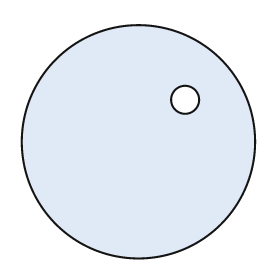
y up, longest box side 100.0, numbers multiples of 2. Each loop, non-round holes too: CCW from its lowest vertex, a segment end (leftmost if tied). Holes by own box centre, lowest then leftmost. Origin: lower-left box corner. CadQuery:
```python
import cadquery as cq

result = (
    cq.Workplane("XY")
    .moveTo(50.0, 50.0)
    .circle(50.0)
    .moveTo(70.0, 68.0)
    .circle(6.0)
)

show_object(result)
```